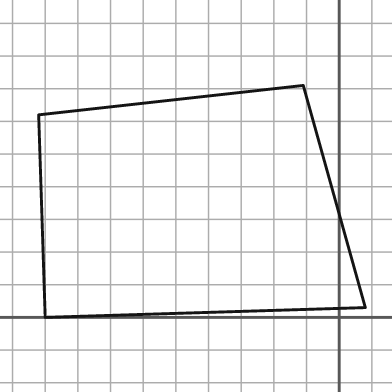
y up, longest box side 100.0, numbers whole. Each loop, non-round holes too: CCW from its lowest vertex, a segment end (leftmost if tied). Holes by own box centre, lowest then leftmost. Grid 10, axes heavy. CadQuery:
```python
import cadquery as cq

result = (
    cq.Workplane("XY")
    .moveTo(-90.0, 0.0)
    .lineTo(8.0, 3.0)
    .lineTo(-11.0, 71.0)
    .lineTo(-92.0, 62.0)
    .close()
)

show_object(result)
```